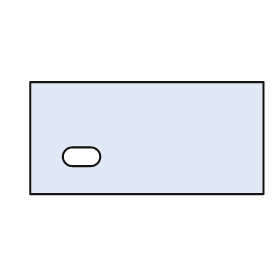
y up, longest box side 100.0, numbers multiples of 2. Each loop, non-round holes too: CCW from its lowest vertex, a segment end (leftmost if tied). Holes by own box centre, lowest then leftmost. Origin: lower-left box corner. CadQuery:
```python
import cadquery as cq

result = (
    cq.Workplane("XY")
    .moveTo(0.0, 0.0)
    .lineTo(100.0, 0.0)
    .lineTo(100.0, 48.0)
    .lineTo(0.0, 48.0)
    .close()
    .moveTo(18.0, 12.0)
    .lineTo(26.0, 12.0)
    .threePointArc((30.0, 16.0), (26.0, 20.0))
    .lineTo(18.0, 20.0)
    .threePointArc((14.0, 16.0), (18.0, 12.0))
    .close()
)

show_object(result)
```